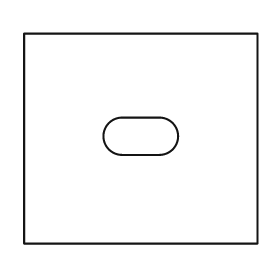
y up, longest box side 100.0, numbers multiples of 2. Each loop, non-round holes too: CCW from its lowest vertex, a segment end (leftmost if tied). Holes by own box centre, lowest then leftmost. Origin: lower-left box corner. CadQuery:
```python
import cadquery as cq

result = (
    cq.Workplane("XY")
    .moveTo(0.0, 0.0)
    .lineTo(100.0, 0.0)
    .lineTo(100.0, 90.0)
    .lineTo(0.0, 90.0)
    .close()
    .moveTo(42.0, 38.0)
    .lineTo(58.0, 38.0)
    .threePointArc((66.0, 46.0), (58.0, 54.0))
    .lineTo(42.0, 54.0)
    .threePointArc((34.0, 46.0), (42.0, 38.0))
    .close()
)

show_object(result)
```